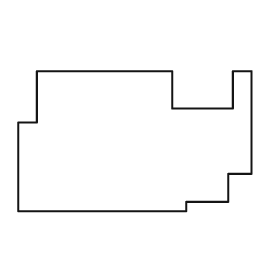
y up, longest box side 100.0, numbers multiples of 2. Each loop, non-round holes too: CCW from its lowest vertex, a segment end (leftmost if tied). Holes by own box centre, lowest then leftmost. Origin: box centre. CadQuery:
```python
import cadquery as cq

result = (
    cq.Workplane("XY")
    .moveTo(-50.0, -30.0)
    .lineTo(22.0, -30.0)
    .lineTo(22.0, -26.0)
    .lineTo(40.0, -26.0)
    .lineTo(40.0, -14.0)
    .lineTo(50.0, -14.0)
    .lineTo(50.0, 30.0)
    .lineTo(42.0, 30.0)
    .lineTo(42.0, 14.0)
    .lineTo(16.0, 14.0)
    .lineTo(16.0, 30.0)
    .lineTo(-42.0, 30.0)
    .lineTo(-42.0, 8.0)
    .lineTo(-50.0, 8.0)
    .close()
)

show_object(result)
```